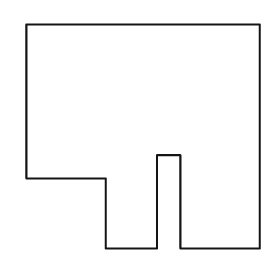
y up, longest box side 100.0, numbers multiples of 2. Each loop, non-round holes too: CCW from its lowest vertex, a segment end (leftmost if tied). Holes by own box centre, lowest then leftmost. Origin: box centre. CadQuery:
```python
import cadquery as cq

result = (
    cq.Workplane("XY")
    .moveTo(-16.0, -48.0)
    .lineTo(6.0, -48.0)
    .lineTo(6.0, -8.0)
    .lineTo(16.0, -8.0)
    .lineTo(16.0, -48.0)
    .lineTo(50.0, -48.0)
    .lineTo(50.0, 48.0)
    .lineTo(-50.0, 48.0)
    .lineTo(-50.0, -18.0)
    .lineTo(-16.0, -18.0)
    .close()
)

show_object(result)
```